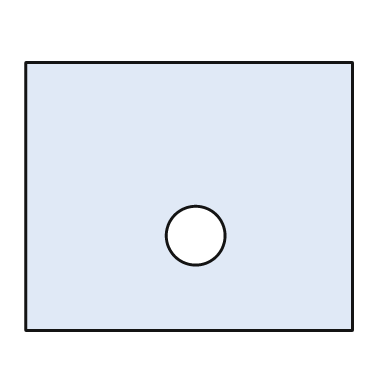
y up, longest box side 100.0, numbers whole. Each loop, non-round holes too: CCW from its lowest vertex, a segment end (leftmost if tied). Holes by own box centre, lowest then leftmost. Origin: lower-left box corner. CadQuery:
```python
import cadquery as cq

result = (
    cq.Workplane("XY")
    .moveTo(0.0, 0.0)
    .lineTo(100.0, 0.0)
    .lineTo(100.0, 82.0)
    .lineTo(0.0, 82.0)
    .close()
    .moveTo(52.0, 29.0)
    .circle(9.0)
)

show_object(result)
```